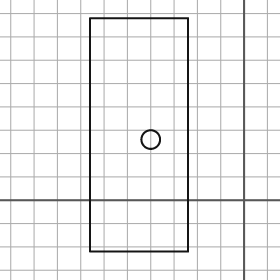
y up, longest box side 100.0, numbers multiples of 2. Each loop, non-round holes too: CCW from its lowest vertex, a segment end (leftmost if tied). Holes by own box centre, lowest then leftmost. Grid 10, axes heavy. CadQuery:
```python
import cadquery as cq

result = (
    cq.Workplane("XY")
    .moveTo(-66.0, -22.0)
    .lineTo(-24.0, -22.0)
    .lineTo(-24.0, 78.0)
    .lineTo(-66.0, 78.0)
    .close()
    .moveTo(-40.0, 26.0)
    .circle(4.0)
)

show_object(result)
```